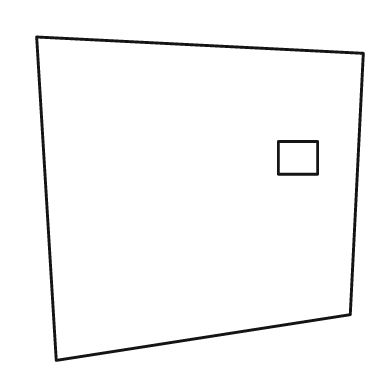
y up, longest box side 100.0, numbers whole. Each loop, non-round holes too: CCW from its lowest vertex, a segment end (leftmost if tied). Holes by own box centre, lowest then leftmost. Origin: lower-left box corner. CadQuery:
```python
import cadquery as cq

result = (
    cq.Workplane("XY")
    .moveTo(6.0, 0.0)
    .lineTo(96.0, 14.0)
    .lineTo(100.0, 94.0)
    .lineTo(0.0, 99.0)
    .close()
    .moveTo(74.0, 57.0)
    .lineTo(86.0, 57.0)
    .lineTo(86.0, 67.0)
    .lineTo(74.0, 67.0)
    .close()
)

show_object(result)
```